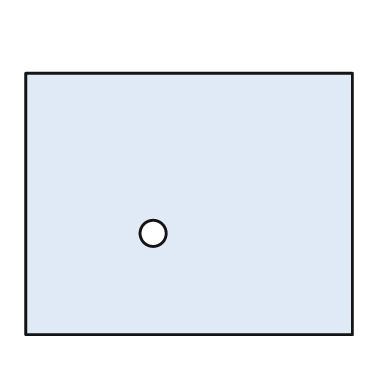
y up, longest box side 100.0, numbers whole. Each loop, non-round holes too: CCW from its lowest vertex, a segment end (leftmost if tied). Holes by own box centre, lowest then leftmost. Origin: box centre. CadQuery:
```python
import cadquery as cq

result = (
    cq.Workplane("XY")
    .moveTo(-50.0, -40.0)
    .lineTo(50.0, -40.0)
    .lineTo(50.0, 40.0)
    .lineTo(-50.0, 40.0)
    .close()
    .moveTo(-11.0, -9.0)
    .circle(4.0)
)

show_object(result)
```